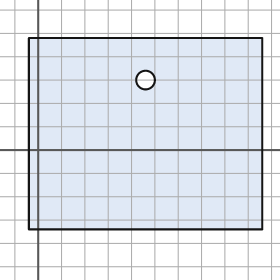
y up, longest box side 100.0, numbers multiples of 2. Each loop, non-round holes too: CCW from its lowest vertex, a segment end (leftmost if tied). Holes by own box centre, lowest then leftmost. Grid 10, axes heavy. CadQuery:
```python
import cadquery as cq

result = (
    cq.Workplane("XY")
    .moveTo(-4.0, -34.0)
    .lineTo(96.0, -34.0)
    .lineTo(96.0, 48.0)
    .lineTo(-4.0, 48.0)
    .close()
    .moveTo(46.0, 30.0)
    .circle(4.0)
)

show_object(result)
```